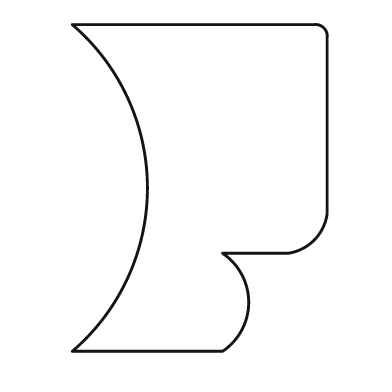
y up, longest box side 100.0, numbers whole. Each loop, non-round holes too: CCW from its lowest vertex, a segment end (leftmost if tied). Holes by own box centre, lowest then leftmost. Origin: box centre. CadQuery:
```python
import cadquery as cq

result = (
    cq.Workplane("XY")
    .moveTo(-39.0, -50.0)
    .lineTo(7.0, -50.0)
    .threePointArc((15.0, -35.0), (7.0, -20.0))
    .lineTo(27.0, -20.0)
    .threePointArc((35.0, -16.0), (39.0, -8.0))
    .lineTo(39.0, 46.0)
    .threePointArc((38.0, 49.0), (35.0, 50.0))
    .lineTo(-39.0, 50.0)
    .threePointArc((-16.0, 0.0), (-39.0, -50.0))
    .close()
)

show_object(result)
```